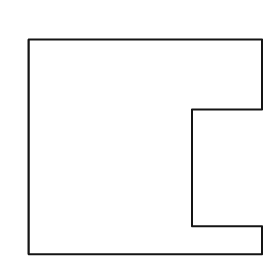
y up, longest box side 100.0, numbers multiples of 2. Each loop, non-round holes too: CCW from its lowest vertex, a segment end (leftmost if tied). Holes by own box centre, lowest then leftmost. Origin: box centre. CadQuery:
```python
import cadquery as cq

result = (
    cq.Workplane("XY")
    .moveTo(-50.0, -46.0)
    .lineTo(50.0, -46.0)
    .lineTo(50.0, -34.0)
    .lineTo(20.0, -34.0)
    .lineTo(20.0, 16.0)
    .lineTo(50.0, 16.0)
    .lineTo(50.0, 46.0)
    .lineTo(-50.0, 46.0)
    .close()
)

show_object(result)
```